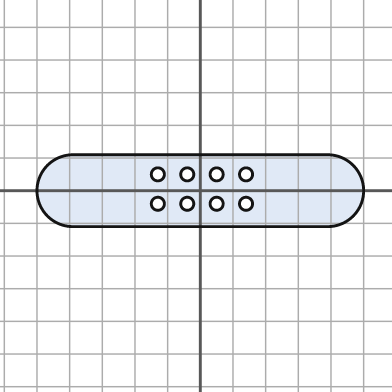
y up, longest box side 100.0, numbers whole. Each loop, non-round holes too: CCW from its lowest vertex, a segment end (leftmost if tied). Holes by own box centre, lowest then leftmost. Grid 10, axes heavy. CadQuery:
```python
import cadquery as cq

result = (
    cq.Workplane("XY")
    .moveTo(-39.0, -11.0)
    .lineTo(39.0, -11.0)
    .threePointArc((50.0, 0.0), (39.0, 11.0))
    .lineTo(-39.0, 11.0)
    .threePointArc((-50.0, 0.0), (-39.0, -11.0))
    .close()
    .moveTo(-13.0, -4.0)
    .circle(2.0)
    .moveTo(-4.0, -4.0)
    .circle(2.0)
    .moveTo(5.0, -4.0)
    .circle(2.0)
    .moveTo(14.0, -4.0)
    .circle(2.0)
    .moveTo(-13.0, 5.0)
    .circle(2.0)
    .moveTo(-4.0, 5.0)
    .circle(2.0)
    .moveTo(5.0, 5.0)
    .circle(2.0)
    .moveTo(14.0, 5.0)
    .circle(2.0)
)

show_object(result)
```